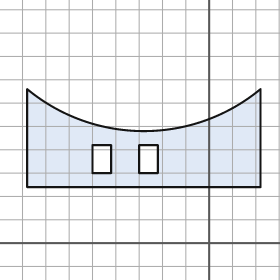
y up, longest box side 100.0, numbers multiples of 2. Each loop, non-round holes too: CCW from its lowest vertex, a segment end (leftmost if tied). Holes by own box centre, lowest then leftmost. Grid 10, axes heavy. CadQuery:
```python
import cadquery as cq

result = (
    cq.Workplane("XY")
    .moveTo(-78.0, 24.0)
    .lineTo(22.0, 24.0)
    .lineTo(22.0, 66.0)
    .threePointArc((-28.0, 48.0), (-78.0, 66.0))
    .close()
    .moveTo(-50.0, 30.0)
    .lineTo(-42.0, 30.0)
    .lineTo(-42.0, 42.0)
    .lineTo(-50.0, 42.0)
    .close()
    .moveTo(-30.0, 30.0)
    .lineTo(-22.0, 30.0)
    .lineTo(-22.0, 42.0)
    .lineTo(-30.0, 42.0)
    .close()
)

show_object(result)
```